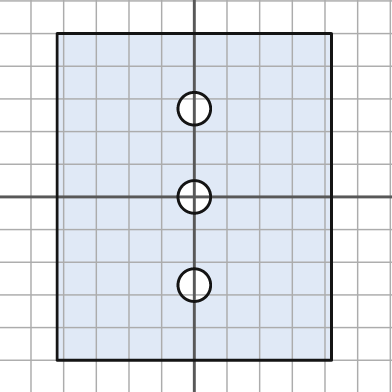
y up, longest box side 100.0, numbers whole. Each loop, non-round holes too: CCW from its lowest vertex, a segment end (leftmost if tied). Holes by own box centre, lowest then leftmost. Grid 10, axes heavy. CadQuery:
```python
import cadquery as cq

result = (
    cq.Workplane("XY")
    .moveTo(-42.0, -50.0)
    .lineTo(42.0, -50.0)
    .lineTo(42.0, 50.0)
    .lineTo(-42.0, 50.0)
    .close()
    .moveTo(0.0, -27.0)
    .circle(5.0)
    .moveTo(0.0, 0.0)
    .circle(5.0)
    .moveTo(0.0, 27.0)
    .circle(5.0)
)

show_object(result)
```